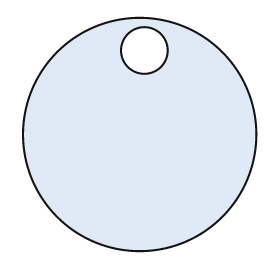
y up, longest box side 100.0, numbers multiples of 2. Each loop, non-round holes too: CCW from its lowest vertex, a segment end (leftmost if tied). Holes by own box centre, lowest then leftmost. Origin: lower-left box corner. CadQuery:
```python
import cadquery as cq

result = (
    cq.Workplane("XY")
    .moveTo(50.0, 50.0)
    .circle(50.0)
    .moveTo(52.0, 86.0)
    .circle(10.0)
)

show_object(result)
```